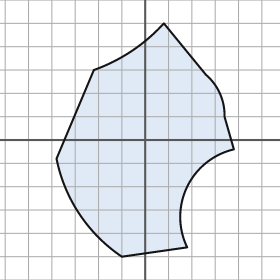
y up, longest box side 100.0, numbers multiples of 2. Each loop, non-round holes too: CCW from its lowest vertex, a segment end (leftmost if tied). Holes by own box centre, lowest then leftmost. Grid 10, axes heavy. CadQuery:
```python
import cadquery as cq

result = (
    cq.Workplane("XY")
    .moveTo(-10.0, -50.0)
    .lineTo(18.0, -46.0)
    .threePointArc((18.0, -20.0), (38.0, -4.0))
    .lineTo(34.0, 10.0)
    .threePointArc((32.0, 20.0), (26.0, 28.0))
    .lineTo(8.0, 50.0)
    .threePointArc((-6.0, 38.0), (-22.0, 30.0))
    .lineTo(-38.0, -8.0)
    .threePointArc((-28.0, -32.0), (-10.0, -50.0))
    .close()
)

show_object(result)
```